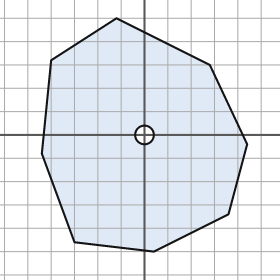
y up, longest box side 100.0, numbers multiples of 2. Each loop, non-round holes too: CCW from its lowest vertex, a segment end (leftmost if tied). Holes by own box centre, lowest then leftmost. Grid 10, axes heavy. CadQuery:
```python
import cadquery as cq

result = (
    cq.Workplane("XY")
    .moveTo(4.0, -50.0)
    .lineTo(36.0, -34.0)
    .lineTo(44.0, -4.0)
    .lineTo(28.0, 30.0)
    .lineTo(-12.0, 50.0)
    .lineTo(-40.0, 32.0)
    .lineTo(-44.0, -8.0)
    .lineTo(-30.0, -46.0)
    .close()
    .moveTo(0.0, 0.0)
    .circle(4.0)
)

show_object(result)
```